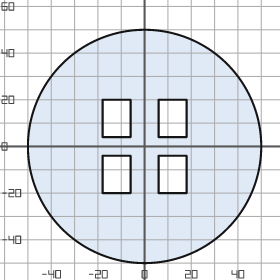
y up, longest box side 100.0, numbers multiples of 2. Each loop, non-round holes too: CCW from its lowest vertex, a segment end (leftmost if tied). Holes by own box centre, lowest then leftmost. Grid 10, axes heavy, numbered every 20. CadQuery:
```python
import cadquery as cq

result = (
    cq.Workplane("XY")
    .moveTo(0.0, 0.0)
    .circle(50.0)
    .moveTo(-18.0, -20.0)
    .lineTo(-6.0, -20.0)
    .lineTo(-6.0, -4.0)
    .lineTo(-18.0, -4.0)
    .close()
    .moveTo(6.0, -20.0)
    .lineTo(18.0, -20.0)
    .lineTo(18.0, -4.0)
    .lineTo(6.0, -4.0)
    .close()
    .moveTo(-18.0, 4.0)
    .lineTo(-6.0, 4.0)
    .lineTo(-6.0, 20.0)
    .lineTo(-18.0, 20.0)
    .close()
    .moveTo(6.0, 4.0)
    .lineTo(18.0, 4.0)
    .lineTo(18.0, 20.0)
    .lineTo(6.0, 20.0)
    .close()
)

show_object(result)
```